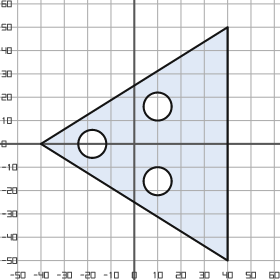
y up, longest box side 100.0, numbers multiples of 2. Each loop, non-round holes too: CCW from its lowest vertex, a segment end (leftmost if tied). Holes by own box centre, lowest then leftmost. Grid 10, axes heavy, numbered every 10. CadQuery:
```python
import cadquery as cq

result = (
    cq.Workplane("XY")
    .moveTo(40.0, -50.0)
    .lineTo(40.0, 50.0)
    .lineTo(-40.0, 0.0)
    .close()
    .moveTo(10.0, -16.0)
    .circle(6.0)
    .moveTo(-18.0, 0.0)
    .circle(6.0)
    .moveTo(10.0, 16.0)
    .circle(6.0)
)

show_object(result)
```